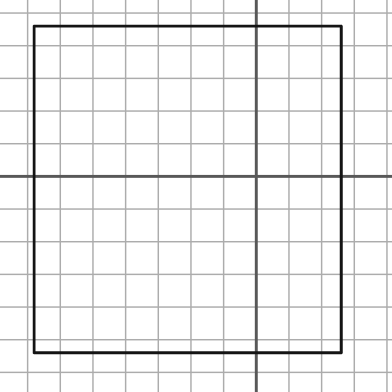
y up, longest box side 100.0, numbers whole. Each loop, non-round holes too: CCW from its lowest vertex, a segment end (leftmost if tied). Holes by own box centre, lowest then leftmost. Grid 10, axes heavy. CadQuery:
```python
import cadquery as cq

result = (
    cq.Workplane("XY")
    .moveTo(-68.0, -54.0)
    .lineTo(26.0, -54.0)
    .lineTo(26.0, 46.0)
    .lineTo(-68.0, 46.0)
    .close()
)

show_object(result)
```